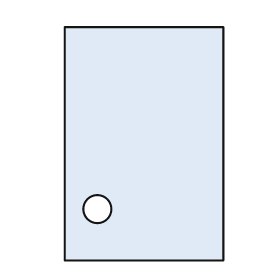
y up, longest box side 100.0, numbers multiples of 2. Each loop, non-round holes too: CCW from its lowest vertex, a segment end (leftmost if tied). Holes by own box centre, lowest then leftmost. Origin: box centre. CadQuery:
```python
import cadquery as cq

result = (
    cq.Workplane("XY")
    .moveTo(-34.0, -50.0)
    .lineTo(34.0, -50.0)
    .lineTo(34.0, 50.0)
    .lineTo(-34.0, 50.0)
    .close()
    .moveTo(-20.0, -28.0)
    .circle(6.0)
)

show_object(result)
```